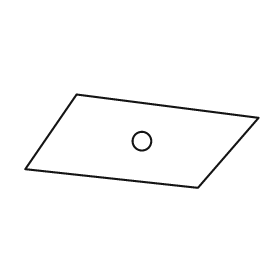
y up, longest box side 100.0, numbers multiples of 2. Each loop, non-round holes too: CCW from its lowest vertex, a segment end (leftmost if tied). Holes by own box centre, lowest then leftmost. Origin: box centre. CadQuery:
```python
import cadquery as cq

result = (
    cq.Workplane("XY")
    .moveTo(24.0, -20.0)
    .lineTo(50.0, 10.0)
    .lineTo(-28.0, 20.0)
    .lineTo(-50.0, -12.0)
    .close()
    .moveTo(0.0, 0.0)
    .circle(4.0)
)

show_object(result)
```